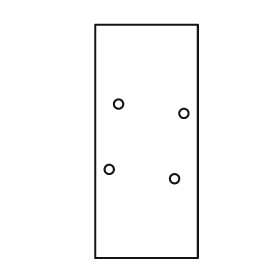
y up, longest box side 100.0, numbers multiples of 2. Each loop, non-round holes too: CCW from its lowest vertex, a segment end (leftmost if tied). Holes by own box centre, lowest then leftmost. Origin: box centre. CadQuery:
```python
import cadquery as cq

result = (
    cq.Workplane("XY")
    .moveTo(-22.0, -50.0)
    .lineTo(22.0, -50.0)
    .lineTo(22.0, 50.0)
    .lineTo(-22.0, 50.0)
    .close()
    .moveTo(12.0, -16.0)
    .circle(2.0)
    .moveTo(-16.0, -12.0)
    .circle(2.0)
    .moveTo(16.0, 12.0)
    .circle(2.0)
    .moveTo(-12.0, 16.0)
    .circle(2.0)
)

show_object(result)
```